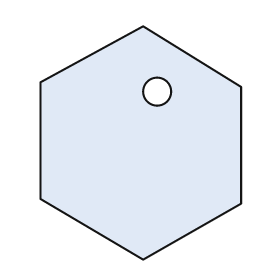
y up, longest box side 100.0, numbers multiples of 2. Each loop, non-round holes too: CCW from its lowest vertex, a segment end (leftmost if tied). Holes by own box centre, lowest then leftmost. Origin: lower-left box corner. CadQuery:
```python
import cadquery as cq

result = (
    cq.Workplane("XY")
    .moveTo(44.0, 0.0)
    .lineTo(86.0, 24.0)
    .lineTo(86.0, 74.0)
    .lineTo(44.0, 100.0)
    .lineTo(0.0, 76.0)
    .lineTo(0.0, 26.0)
    .close()
    .moveTo(50.0, 72.0)
    .circle(6.0)
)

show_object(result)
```